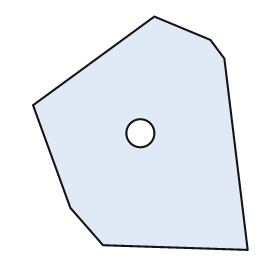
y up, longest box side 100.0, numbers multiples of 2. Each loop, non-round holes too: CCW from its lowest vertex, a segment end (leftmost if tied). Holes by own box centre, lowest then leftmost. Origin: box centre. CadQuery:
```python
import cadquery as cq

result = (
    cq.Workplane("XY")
    .moveTo(46.0, -50.0)
    .lineTo(36.0, 32.0)
    .lineTo(30.0, 40.0)
    .lineTo(6.0, 50.0)
    .lineTo(-46.0, 12.0)
    .lineTo(-30.0, -32.0)
    .lineTo(-16.0, -48.0)
    .close()
    .moveTo(0.0, 0.0)
    .circle(6.0)
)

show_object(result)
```